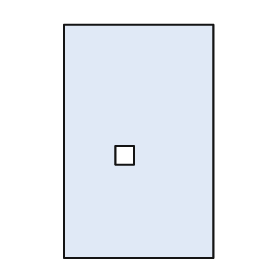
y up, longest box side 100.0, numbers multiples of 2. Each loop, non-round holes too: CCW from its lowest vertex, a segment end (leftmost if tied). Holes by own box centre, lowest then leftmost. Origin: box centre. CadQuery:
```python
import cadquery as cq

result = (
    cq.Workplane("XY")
    .moveTo(-32.0, -50.0)
    .lineTo(32.0, -50.0)
    .lineTo(32.0, 50.0)
    .lineTo(-32.0, 50.0)
    .close()
    .moveTo(-10.0, -10.0)
    .lineTo(-2.0, -10.0)
    .lineTo(-2.0, -2.0)
    .lineTo(-10.0, -2.0)
    .close()
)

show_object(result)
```